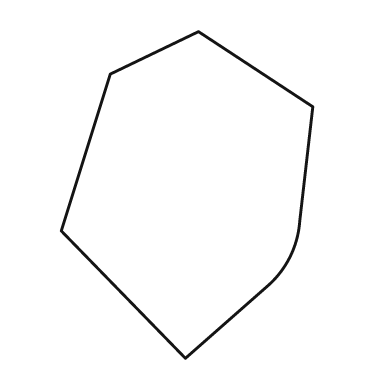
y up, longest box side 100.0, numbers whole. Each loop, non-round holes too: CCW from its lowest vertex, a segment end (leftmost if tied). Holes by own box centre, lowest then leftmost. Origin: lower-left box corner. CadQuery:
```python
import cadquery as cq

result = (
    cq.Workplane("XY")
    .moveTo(38.0, 0.0)
    .lineTo(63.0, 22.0)
    .threePointArc((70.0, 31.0), (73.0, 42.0))
    .lineTo(77.0, 77.0)
    .lineTo(42.0, 100.0)
    .lineTo(15.0, 87.0)
    .lineTo(0.0, 39.0)
    .close()
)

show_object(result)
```